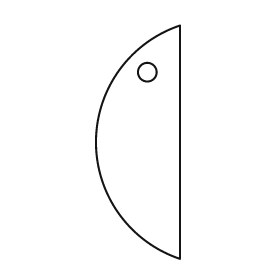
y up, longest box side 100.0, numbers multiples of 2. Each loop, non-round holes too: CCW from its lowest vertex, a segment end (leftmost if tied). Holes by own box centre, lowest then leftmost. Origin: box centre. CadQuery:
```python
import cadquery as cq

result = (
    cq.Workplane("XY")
    .moveTo(18.0, -50.0)
    .lineTo(18.0, 50.0)
    .threePointArc((-18.0, 0.0), (18.0, -50.0))
    .close()
    .moveTo(4.0, 30.0)
    .circle(4.0)
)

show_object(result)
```